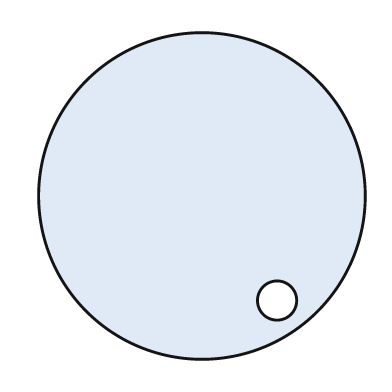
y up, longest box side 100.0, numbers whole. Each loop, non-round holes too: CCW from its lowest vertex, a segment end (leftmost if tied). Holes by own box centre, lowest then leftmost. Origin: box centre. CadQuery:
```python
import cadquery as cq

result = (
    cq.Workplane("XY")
    .moveTo(0.0, 0.0)
    .circle(50.0)
    .moveTo(23.0, -32.0)
    .circle(6.0)
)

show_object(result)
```